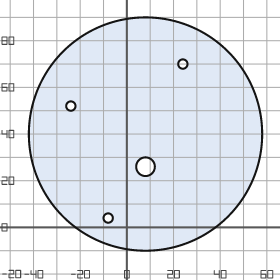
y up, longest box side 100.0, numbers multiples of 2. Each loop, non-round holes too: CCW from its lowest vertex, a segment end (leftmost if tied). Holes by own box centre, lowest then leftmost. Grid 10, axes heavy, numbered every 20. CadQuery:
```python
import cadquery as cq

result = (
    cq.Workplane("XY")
    .moveTo(8.0, 40.0)
    .circle(50.0)
    .moveTo(-8.0, 4.0)
    .circle(2.0)
    .moveTo(8.0, 26.0)
    .circle(4.0)
    .moveTo(-24.0, 52.0)
    .circle(2.0)
    .moveTo(24.0, 70.0)
    .circle(2.0)
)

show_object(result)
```